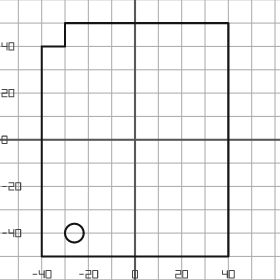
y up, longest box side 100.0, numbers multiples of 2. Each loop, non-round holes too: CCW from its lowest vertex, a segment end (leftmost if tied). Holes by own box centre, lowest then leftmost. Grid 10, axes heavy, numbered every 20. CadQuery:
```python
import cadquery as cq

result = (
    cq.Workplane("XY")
    .moveTo(-40.0, -50.0)
    .lineTo(40.0, -50.0)
    .lineTo(40.0, 50.0)
    .lineTo(-30.0, 50.0)
    .lineTo(-30.0, 40.0)
    .lineTo(-40.0, 40.0)
    .close()
    .moveTo(-26.0, -40.0)
    .circle(4.0)
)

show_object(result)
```